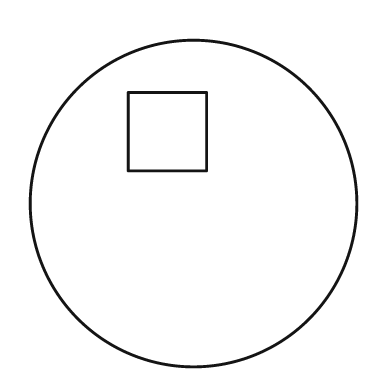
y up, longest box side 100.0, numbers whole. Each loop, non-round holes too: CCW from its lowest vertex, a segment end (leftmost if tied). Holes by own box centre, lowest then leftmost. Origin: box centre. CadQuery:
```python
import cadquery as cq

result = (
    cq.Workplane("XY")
    .moveTo(0.0, 0.0)
    .circle(50.0)
    .moveTo(-20.0, 10.0)
    .lineTo(4.0, 10.0)
    .lineTo(4.0, 34.0)
    .lineTo(-20.0, 34.0)
    .close()
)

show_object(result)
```